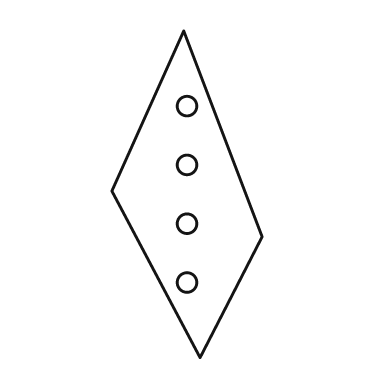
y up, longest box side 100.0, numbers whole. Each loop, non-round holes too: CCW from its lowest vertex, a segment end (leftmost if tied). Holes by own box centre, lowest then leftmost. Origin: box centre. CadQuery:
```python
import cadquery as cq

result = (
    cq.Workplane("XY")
    .moveTo(4.0, -50.0)
    .lineTo(23.0, -13.0)
    .lineTo(-1.0, 50.0)
    .lineTo(-23.0, 1.0)
    .close()
    .moveTo(0.0, -27.0)
    .circle(3.0)
    .moveTo(0.0, -9.0)
    .circle(3.0)
    .moveTo(0.0, 9.0)
    .circle(3.0)
    .moveTo(0.0, 27.0)
    .circle(3.0)
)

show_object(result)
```